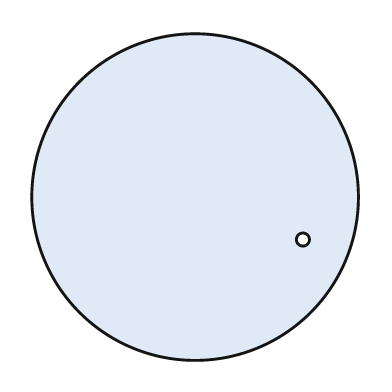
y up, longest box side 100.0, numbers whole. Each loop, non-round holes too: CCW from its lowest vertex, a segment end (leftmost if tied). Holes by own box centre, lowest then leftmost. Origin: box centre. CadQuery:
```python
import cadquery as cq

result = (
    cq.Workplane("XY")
    .moveTo(0.0, 0.0)
    .circle(50.0)
    .moveTo(33.0, -13.0)
    .circle(2.0)
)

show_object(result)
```